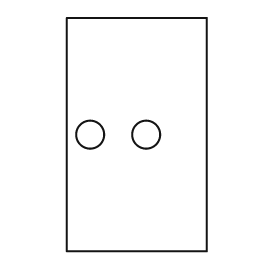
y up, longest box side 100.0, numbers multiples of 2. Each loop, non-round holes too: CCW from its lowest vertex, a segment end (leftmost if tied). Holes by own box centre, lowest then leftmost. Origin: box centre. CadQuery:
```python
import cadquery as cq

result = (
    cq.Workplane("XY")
    .moveTo(-30.0, -50.0)
    .lineTo(30.0, -50.0)
    .lineTo(30.0, 50.0)
    .lineTo(-30.0, 50.0)
    .close()
    .moveTo(-20.0, 0.0)
    .circle(6.0)
    .moveTo(4.0, 0.0)
    .circle(6.0)
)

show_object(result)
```